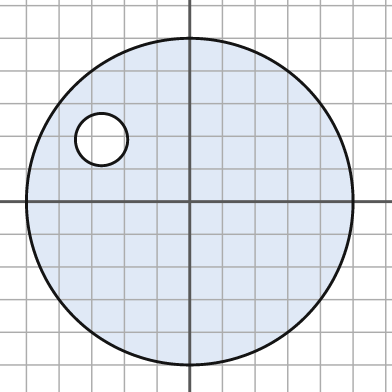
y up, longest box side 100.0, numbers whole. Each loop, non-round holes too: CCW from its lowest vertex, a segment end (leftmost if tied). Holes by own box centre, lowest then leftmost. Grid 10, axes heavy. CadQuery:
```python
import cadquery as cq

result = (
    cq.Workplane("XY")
    .moveTo(0.0, 0.0)
    .circle(50.0)
    .moveTo(-27.0, 19.0)
    .circle(8.0)
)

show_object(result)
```